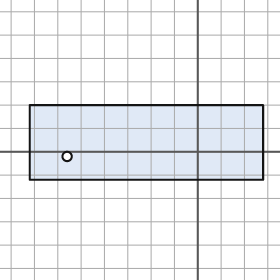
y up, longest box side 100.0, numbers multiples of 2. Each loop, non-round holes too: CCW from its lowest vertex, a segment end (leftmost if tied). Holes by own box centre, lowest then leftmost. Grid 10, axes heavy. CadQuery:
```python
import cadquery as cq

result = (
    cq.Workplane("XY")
    .moveTo(-72.0, -12.0)
    .lineTo(28.0, -12.0)
    .lineTo(28.0, 20.0)
    .lineTo(-72.0, 20.0)
    .close()
    .moveTo(-56.0, -2.0)
    .circle(2.0)
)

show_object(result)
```